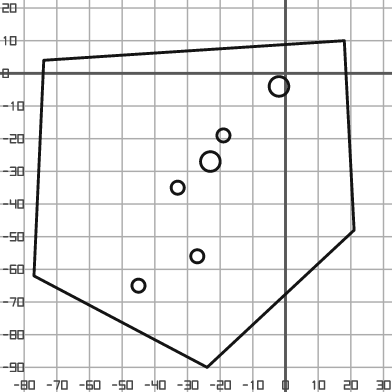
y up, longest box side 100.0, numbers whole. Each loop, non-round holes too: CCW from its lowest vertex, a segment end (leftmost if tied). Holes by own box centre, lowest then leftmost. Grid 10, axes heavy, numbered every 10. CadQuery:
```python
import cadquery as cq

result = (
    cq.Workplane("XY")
    .moveTo(-24.0, -90.0)
    .lineTo(21.0, -48.0)
    .lineTo(18.0, 10.0)
    .lineTo(-74.0, 4.0)
    .lineTo(-77.0, -62.0)
    .close()
    .moveTo(-45.0, -65.0)
    .circle(2.0)
    .moveTo(-27.0, -56.0)
    .circle(2.0)
    .moveTo(-33.0, -35.0)
    .circle(2.0)
    .moveTo(-23.0, -27.0)
    .circle(3.0)
    .moveTo(-19.0, -19.0)
    .circle(2.0)
    .moveTo(-2.0, -4.0)
    .circle(3.0)
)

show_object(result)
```